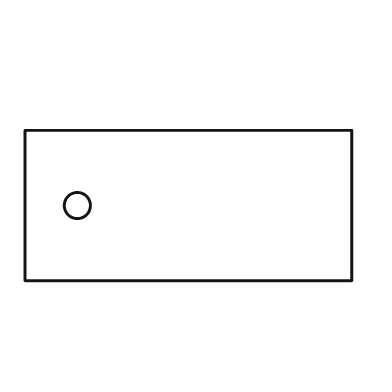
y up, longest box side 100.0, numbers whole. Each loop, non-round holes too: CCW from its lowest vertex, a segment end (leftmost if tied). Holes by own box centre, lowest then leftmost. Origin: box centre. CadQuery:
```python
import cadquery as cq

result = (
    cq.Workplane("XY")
    .moveTo(-50.0, -23.0)
    .lineTo(50.0, -23.0)
    .lineTo(50.0, 23.0)
    .lineTo(-50.0, 23.0)
    .close()
    .moveTo(-34.0, 0.0)
    .circle(4.0)
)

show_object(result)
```